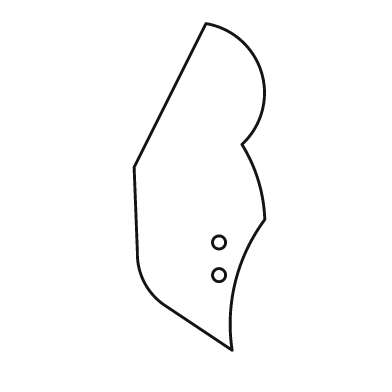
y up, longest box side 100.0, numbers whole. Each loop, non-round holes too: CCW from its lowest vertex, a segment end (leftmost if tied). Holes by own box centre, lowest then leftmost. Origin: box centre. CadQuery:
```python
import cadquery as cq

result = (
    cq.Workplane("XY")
    .moveTo(10.0, -50.0)
    .threePointArc((11.0, -29.0), (20.0, -10.0))
    .threePointArc((18.0, 2.0), (13.0, 13.0))
    .threePointArc((19.0, 35.0), (2.0, 50.0))
    .lineTo(-20.0, 6.0)
    .lineTo(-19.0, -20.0)
    .threePointArc((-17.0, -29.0), (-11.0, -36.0))
    .close()
    .moveTo(6.0, -27.0)
    .circle(2.0)
    .moveTo(6.0, -17.0)
    .circle(2.0)
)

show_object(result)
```